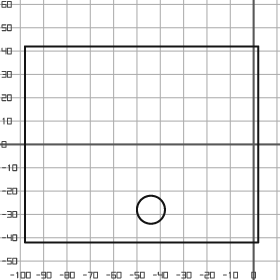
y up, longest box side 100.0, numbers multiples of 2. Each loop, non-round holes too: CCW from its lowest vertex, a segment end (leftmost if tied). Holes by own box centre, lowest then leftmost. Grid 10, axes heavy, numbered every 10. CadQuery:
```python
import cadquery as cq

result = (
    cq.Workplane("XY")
    .moveTo(-98.0, -42.0)
    .lineTo(2.0, -42.0)
    .lineTo(2.0, 42.0)
    .lineTo(-98.0, 42.0)
    .close()
    .moveTo(-44.0, -28.0)
    .circle(6.0)
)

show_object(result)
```